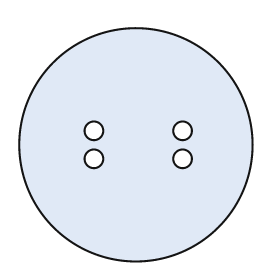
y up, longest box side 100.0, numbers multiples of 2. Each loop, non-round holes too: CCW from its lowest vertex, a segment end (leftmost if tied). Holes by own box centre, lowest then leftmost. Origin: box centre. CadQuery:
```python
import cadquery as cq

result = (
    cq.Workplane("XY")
    .moveTo(0.0, 0.0)
    .circle(50.0)
    .moveTo(-18.0, -6.0)
    .circle(4.0)
    .moveTo(20.0, -6.0)
    .circle(4.0)
    .moveTo(-18.0, 6.0)
    .circle(4.0)
    .moveTo(20.0, 6.0)
    .circle(4.0)
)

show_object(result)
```